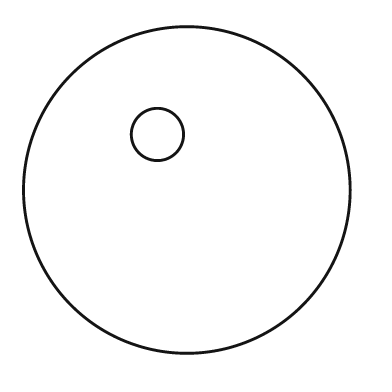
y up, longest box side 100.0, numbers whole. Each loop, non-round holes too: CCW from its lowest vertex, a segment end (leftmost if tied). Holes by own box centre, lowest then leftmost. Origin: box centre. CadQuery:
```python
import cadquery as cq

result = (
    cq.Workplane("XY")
    .moveTo(0.0, 0.0)
    .circle(50.0)
    .moveTo(-9.0, 17.0)
    .circle(8.0)
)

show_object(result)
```